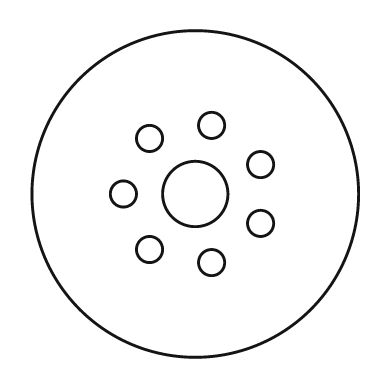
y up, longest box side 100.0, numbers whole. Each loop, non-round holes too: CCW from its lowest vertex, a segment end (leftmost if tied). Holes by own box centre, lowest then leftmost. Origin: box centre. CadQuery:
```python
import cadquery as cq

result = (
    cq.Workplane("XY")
    .moveTo(0.0, 0.0)
    .circle(50.0)
    .moveTo(5.0, -21.0)
    .circle(4.0)
    .moveTo(-14.0, -17.0)
    .circle(4.0)
    .moveTo(20.0, -9.0)
    .circle(4.0)
    .moveTo(-22.0, 0.0)
    .circle(4.0)
    .moveTo(0.0, 0.0)
    .circle(10.0)
    .moveTo(20.0, 9.0)
    .circle(4.0)
    .moveTo(-14.0, 17.0)
    .circle(4.0)
    .moveTo(5.0, 21.0)
    .circle(4.0)
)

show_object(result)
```